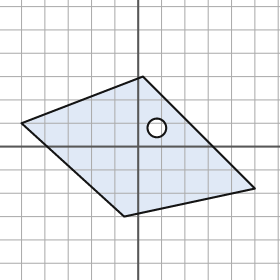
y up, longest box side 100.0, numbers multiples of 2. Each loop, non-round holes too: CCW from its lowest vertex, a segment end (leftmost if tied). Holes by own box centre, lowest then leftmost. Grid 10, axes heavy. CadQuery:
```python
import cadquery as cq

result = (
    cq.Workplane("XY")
    .moveTo(-6.0, -30.0)
    .lineTo(50.0, -18.0)
    .lineTo(2.0, 30.0)
    .lineTo(-50.0, 10.0)
    .close()
    .moveTo(8.0, 8.0)
    .circle(4.0)
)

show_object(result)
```